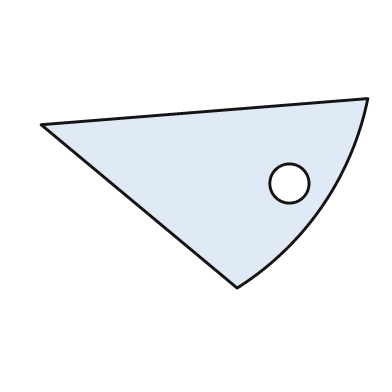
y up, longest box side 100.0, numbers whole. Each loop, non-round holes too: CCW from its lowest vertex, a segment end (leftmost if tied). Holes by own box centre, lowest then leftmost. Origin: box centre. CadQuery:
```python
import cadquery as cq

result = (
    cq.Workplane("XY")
    .moveTo(10.0, -29.0)
    .threePointArc((36.0, -4.0), (50.0, 29.0))
    .lineTo(-50.0, 21.0)
    .close()
    .moveTo(26.0, 3.0)
    .circle(6.0)
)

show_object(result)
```